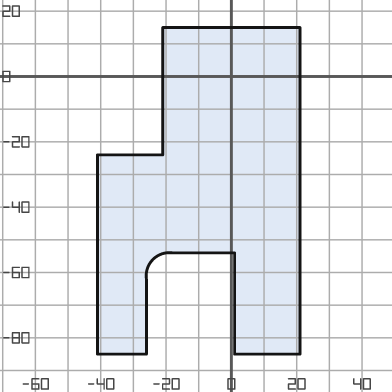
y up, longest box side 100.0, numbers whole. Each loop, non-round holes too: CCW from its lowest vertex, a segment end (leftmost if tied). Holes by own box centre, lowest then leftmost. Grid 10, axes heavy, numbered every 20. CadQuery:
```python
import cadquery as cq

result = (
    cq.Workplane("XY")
    .moveTo(-41.0, -85.0)
    .lineTo(-26.0, -85.0)
    .lineTo(-26.0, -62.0)
    .threePointArc((-24.0, -56.0), (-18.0, -54.0))
    .lineTo(1.0, -54.0)
    .lineTo(1.0, -85.0)
    .lineTo(21.0, -85.0)
    .lineTo(21.0, 15.0)
    .lineTo(-21.0, 15.0)
    .lineTo(-21.0, -24.0)
    .lineTo(-41.0, -24.0)
    .close()
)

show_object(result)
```